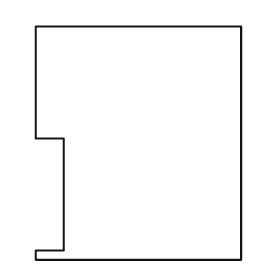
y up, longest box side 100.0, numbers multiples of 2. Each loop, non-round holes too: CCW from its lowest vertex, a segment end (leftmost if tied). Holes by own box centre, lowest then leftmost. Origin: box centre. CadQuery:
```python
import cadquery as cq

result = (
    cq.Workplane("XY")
    .moveTo(-44.0, -50.0)
    .lineTo(44.0, -50.0)
    .lineTo(44.0, 50.0)
    .lineTo(-44.0, 50.0)
    .lineTo(-44.0, 2.0)
    .lineTo(-32.0, 2.0)
    .lineTo(-32.0, -46.0)
    .lineTo(-44.0, -46.0)
    .close()
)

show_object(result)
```